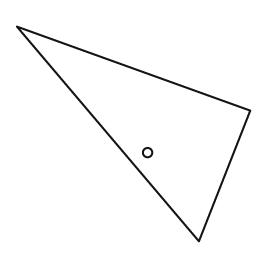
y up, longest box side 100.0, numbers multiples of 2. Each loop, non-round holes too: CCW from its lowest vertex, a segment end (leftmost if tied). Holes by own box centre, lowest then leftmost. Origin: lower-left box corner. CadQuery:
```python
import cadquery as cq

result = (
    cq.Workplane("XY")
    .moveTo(78.0, 0.0)
    .lineTo(100.0, 56.0)
    .lineTo(0.0, 92.0)
    .close()
    .moveTo(56.0, 38.0)
    .circle(2.0)
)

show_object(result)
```